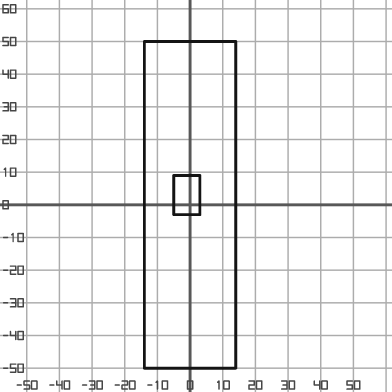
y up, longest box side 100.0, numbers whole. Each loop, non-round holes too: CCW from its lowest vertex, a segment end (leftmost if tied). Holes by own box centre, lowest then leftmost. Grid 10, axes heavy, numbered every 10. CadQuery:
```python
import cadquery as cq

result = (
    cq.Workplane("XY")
    .moveTo(-14.0, -50.0)
    .lineTo(14.0, -50.0)
    .lineTo(14.0, 50.0)
    .lineTo(-14.0, 50.0)
    .close()
    .moveTo(-5.0, -3.0)
    .lineTo(3.0, -3.0)
    .lineTo(3.0, 9.0)
    .lineTo(-5.0, 9.0)
    .close()
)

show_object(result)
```